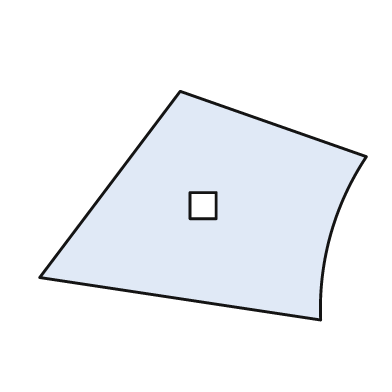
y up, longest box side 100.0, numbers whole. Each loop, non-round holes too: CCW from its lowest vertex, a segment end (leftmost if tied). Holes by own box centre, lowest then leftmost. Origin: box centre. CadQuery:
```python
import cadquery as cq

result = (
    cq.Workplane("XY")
    .moveTo(36.0, -35.0)
    .threePointArc((39.0, -9.0), (50.0, 15.0))
    .lineTo(-7.0, 35.0)
    .lineTo(-50.0, -22.0)
    .close()
    .moveTo(-4.0, -4.0)
    .lineTo(4.0, -4.0)
    .lineTo(4.0, 4.0)
    .lineTo(-4.0, 4.0)
    .close()
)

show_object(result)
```